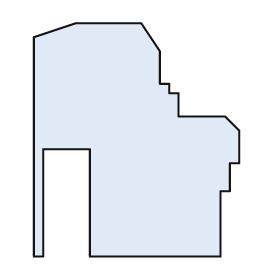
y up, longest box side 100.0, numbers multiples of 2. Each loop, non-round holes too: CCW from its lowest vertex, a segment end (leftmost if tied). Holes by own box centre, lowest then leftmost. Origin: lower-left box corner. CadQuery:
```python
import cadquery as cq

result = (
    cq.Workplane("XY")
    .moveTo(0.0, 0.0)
    .lineTo(4.0, 0.0)
    .lineTo(4.0, 46.0)
    .lineTo(24.0, 46.0)
    .lineTo(24.0, 0.0)
    .lineTo(80.0, 0.0)
    .lineTo(80.0, 28.0)
    .lineTo(84.0, 28.0)
    .lineTo(84.0, 40.0)
    .lineTo(88.0, 40.0)
    .lineTo(88.0, 54.0)
    .lineTo(82.0, 60.0)
    .lineTo(62.0, 60.0)
    .lineTo(62.0, 70.0)
    .lineTo(58.0, 70.0)
    .lineTo(58.0, 74.0)
    .lineTo(54.0, 74.0)
    .lineTo(54.0, 88.0)
    .lineTo(46.0, 100.0)
    .lineTo(18.0, 100.0)
    .lineTo(0.0, 94.0)
    .close()
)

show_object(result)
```